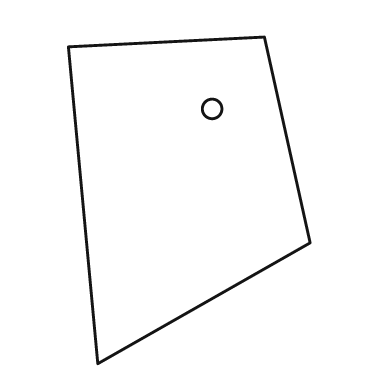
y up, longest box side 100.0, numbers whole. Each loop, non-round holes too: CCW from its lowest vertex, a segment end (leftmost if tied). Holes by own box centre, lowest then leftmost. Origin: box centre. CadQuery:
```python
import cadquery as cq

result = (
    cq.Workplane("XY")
    .moveTo(-28.0, -50.0)
    .lineTo(37.0, -13.0)
    .lineTo(23.0, 50.0)
    .lineTo(-37.0, 47.0)
    .close()
    .moveTo(7.0, 28.0)
    .circle(3.0)
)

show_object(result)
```